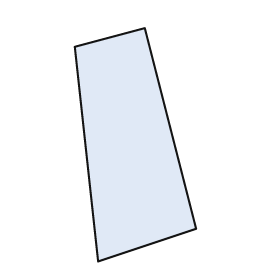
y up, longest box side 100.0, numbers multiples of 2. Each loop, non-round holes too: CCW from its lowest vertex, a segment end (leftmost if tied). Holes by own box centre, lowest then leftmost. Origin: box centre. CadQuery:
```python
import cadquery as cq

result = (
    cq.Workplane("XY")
    .moveTo(-16.0, -50.0)
    .lineTo(26.0, -36.0)
    .lineTo(4.0, 50.0)
    .lineTo(-26.0, 42.0)
    .close()
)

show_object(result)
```